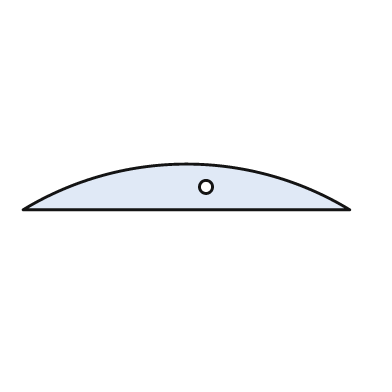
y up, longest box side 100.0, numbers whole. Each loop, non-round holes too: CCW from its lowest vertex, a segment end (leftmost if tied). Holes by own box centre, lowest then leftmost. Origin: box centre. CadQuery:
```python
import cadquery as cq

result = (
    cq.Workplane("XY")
    .moveTo(-50.0, -7.0)
    .lineTo(50.0, -7.0)
    .threePointArc((0.0, 7.0), (-50.0, -7.0))
    .close()
    .moveTo(6.0, 0.0)
    .circle(2.0)
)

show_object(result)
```